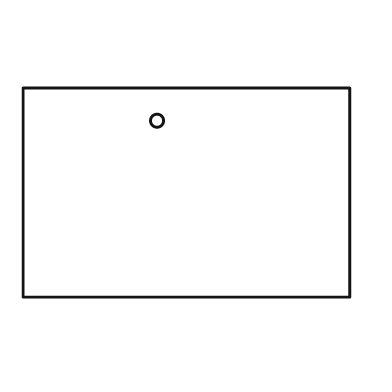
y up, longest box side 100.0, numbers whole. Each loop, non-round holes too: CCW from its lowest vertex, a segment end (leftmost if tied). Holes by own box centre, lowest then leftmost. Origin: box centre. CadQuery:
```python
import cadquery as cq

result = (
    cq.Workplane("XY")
    .moveTo(-50.0, -32.0)
    .lineTo(50.0, -32.0)
    .lineTo(50.0, 32.0)
    .lineTo(-50.0, 32.0)
    .close()
    .moveTo(-9.0, 22.0)
    .circle(2.0)
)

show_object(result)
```